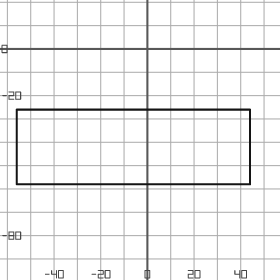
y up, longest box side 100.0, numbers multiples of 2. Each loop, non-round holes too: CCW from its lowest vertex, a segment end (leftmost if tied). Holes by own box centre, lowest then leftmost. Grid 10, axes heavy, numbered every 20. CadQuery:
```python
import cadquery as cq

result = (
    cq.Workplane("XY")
    .moveTo(-56.0, -58.0)
    .lineTo(44.0, -58.0)
    .lineTo(44.0, -26.0)
    .lineTo(-56.0, -26.0)
    .close()
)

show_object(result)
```